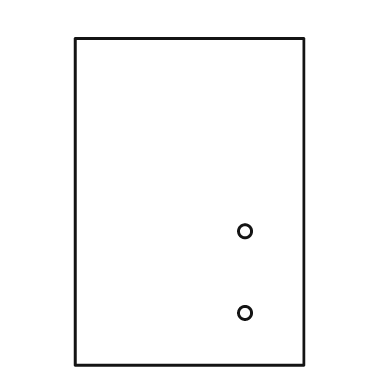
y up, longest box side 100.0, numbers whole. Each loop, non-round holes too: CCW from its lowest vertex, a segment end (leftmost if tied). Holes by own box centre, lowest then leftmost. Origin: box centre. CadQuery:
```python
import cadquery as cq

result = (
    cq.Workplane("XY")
    .moveTo(-35.0, -50.0)
    .lineTo(35.0, -50.0)
    .lineTo(35.0, 50.0)
    .lineTo(-35.0, 50.0)
    .close()
    .moveTo(17.0, -34.0)
    .circle(2.0)
    .moveTo(17.0, -9.0)
    .circle(2.0)
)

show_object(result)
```